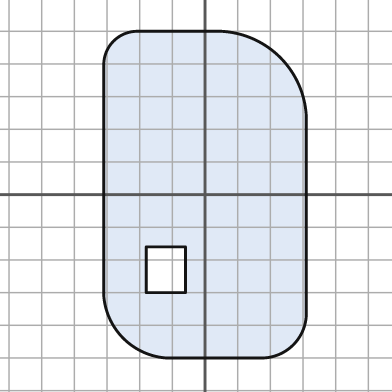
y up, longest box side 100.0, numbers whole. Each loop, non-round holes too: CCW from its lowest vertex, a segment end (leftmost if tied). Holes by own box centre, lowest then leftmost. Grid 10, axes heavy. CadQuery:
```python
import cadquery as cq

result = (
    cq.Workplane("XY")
    .moveTo(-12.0, -50.0)
    .lineTo(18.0, -50.0)
    .threePointArc((27.0, -46.0), (31.0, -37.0))
    .lineTo(31.0, 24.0)
    .threePointArc((23.0, 42.0), (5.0, 50.0))
    .lineTo(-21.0, 50.0)
    .threePointArc((-28.0, 47.0), (-31.0, 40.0))
    .lineTo(-31.0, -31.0)
    .threePointArc((-25.0, -44.0), (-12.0, -50.0))
    .close()
    .moveTo(-18.0, -30.0)
    .lineTo(-6.0, -30.0)
    .lineTo(-6.0, -16.0)
    .lineTo(-18.0, -16.0)
    .close()
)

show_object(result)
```